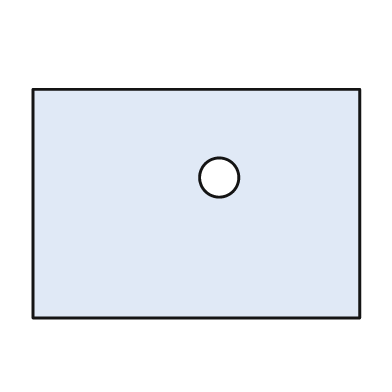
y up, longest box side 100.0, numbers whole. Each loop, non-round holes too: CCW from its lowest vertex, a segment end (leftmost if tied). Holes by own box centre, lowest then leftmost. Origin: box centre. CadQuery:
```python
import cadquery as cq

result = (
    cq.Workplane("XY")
    .moveTo(-50.0, -35.0)
    .lineTo(50.0, -35.0)
    .lineTo(50.0, 35.0)
    .lineTo(-50.0, 35.0)
    .close()
    .moveTo(7.0, 8.0)
    .circle(6.0)
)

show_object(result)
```